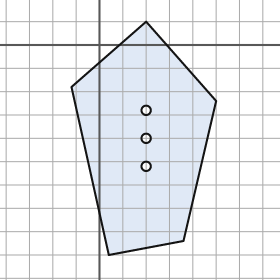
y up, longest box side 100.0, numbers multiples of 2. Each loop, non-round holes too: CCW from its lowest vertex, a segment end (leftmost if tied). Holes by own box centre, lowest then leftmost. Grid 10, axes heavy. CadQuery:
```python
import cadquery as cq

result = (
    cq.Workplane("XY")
    .moveTo(4.0, -90.0)
    .lineTo(36.0, -84.0)
    .lineTo(50.0, -24.0)
    .lineTo(20.0, 10.0)
    .lineTo(-12.0, -18.0)
    .close()
    .moveTo(20.0, -52.0)
    .circle(2.0)
    .moveTo(20.0, -40.0)
    .circle(2.0)
    .moveTo(20.0, -28.0)
    .circle(2.0)
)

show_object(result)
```